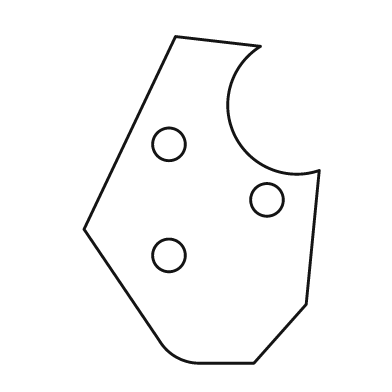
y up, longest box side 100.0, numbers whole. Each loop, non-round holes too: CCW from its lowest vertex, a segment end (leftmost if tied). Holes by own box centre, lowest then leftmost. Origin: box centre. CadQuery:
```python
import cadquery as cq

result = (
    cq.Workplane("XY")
    .moveTo(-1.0, -50.0)
    .lineTo(16.0, -50.0)
    .lineTo(32.0, -32.0)
    .lineTo(36.0, 9.0)
    .threePointArc((10.0, 20.0), (18.0, 47.0))
    .lineTo(-8.0, 50.0)
    .lineTo(-36.0, -9.0)
    .lineTo(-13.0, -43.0)
    .threePointArc((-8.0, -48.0), (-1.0, -50.0))
    .close()
    .moveTo(-10.0, -17.0)
    .circle(5.0)
    .moveTo(20.0, 0.0)
    .circle(5.0)
    .moveTo(-10.0, 17.0)
    .circle(5.0)
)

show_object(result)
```